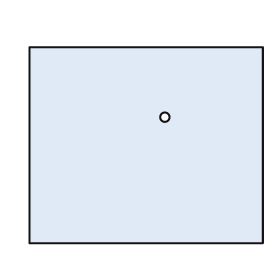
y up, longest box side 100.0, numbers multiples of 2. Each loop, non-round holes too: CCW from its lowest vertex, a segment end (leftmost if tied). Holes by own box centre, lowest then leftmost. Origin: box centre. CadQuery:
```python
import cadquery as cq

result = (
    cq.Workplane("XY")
    .moveTo(-50.0, -42.0)
    .lineTo(50.0, -42.0)
    .lineTo(50.0, 42.0)
    .lineTo(-50.0, 42.0)
    .close()
    .moveTo(8.0, 12.0)
    .circle(2.0)
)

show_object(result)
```